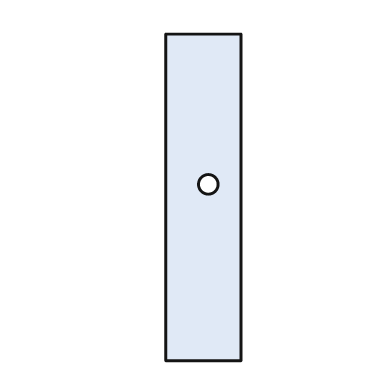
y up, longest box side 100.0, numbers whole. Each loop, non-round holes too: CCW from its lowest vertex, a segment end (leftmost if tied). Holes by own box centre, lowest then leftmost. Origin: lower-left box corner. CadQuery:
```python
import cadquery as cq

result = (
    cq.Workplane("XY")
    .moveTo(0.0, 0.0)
    .lineTo(23.0, 0.0)
    .lineTo(23.0, 100.0)
    .lineTo(0.0, 100.0)
    .close()
    .moveTo(13.0, 54.0)
    .circle(3.0)
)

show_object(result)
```